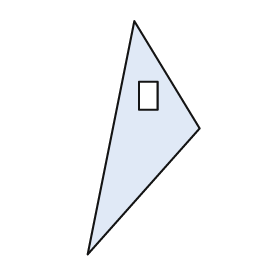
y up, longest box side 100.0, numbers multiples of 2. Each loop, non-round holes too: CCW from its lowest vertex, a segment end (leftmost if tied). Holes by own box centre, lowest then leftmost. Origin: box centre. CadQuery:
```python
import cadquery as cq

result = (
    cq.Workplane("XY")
    .moveTo(-24.0, -50.0)
    .lineTo(24.0, 4.0)
    .lineTo(-4.0, 50.0)
    .close()
    .moveTo(-2.0, 12.0)
    .lineTo(6.0, 12.0)
    .lineTo(6.0, 24.0)
    .lineTo(-2.0, 24.0)
    .close()
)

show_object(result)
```